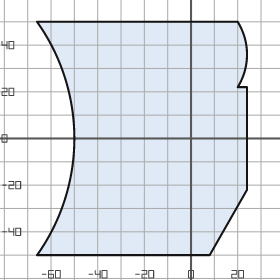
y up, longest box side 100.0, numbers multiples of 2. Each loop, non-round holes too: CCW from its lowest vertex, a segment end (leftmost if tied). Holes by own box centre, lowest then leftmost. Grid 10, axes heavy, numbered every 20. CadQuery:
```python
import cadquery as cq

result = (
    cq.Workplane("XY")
    .moveTo(-66.0, -50.0)
    .lineTo(8.0, -50.0)
    .lineTo(24.0, -22.0)
    .lineTo(24.0, 22.0)
    .lineTo(20.0, 22.0)
    .threePointArc((24.0, 36.0), (20.0, 50.0))
    .lineTo(-66.0, 50.0)
    .threePointArc((-50.0, 0.0), (-66.0, -50.0))
    .close()
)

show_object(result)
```